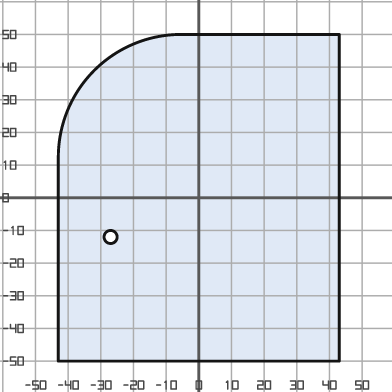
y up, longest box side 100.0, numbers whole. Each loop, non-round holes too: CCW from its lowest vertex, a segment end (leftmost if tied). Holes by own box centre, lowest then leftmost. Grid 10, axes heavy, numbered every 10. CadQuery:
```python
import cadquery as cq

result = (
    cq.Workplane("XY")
    .moveTo(-43.0, -50.0)
    .lineTo(43.0, -50.0)
    .lineTo(43.0, 50.0)
    .lineTo(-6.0, 50.0)
    .threePointArc((-32.0, 39.0), (-43.0, 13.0))
    .close()
    .moveTo(-27.0, -12.0)
    .circle(2.0)
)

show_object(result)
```